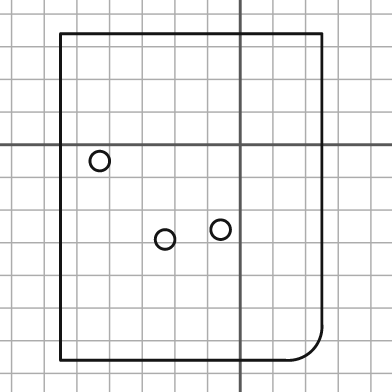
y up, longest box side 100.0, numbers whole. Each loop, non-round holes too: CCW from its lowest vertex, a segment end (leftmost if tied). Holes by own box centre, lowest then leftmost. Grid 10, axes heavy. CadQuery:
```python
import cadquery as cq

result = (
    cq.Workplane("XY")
    .moveTo(-55.0, -66.0)
    .lineTo(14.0, -66.0)
    .threePointArc((22.0, -63.0), (25.0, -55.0))
    .lineTo(25.0, 34.0)
    .lineTo(-55.0, 34.0)
    .close()
    .moveTo(-23.0, -29.0)
    .circle(3.0)
    .moveTo(-6.0, -26.0)
    .circle(3.0)
    .moveTo(-43.0, -5.0)
    .circle(3.0)
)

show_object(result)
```